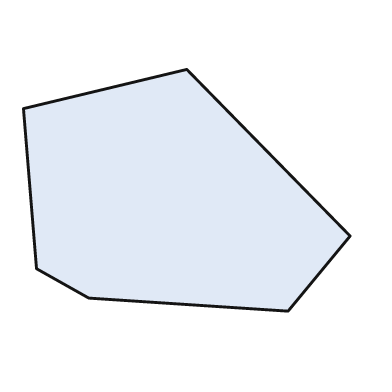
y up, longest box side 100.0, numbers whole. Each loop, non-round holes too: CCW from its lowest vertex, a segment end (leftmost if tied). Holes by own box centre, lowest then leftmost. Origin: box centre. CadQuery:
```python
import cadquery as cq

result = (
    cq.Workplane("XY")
    .moveTo(31.0, -37.0)
    .lineTo(50.0, -14.0)
    .lineTo(0.0, 37.0)
    .lineTo(-50.0, 25.0)
    .lineTo(-46.0, -24.0)
    .lineTo(-30.0, -33.0)
    .close()
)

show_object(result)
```